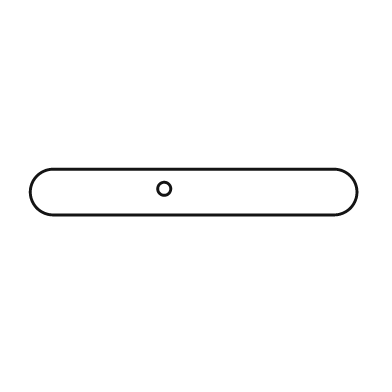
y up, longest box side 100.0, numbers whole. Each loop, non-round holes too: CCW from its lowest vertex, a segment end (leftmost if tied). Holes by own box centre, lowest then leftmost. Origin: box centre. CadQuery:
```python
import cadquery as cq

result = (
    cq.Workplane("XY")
    .moveTo(-43.0, -7.0)
    .lineTo(43.0, -7.0)
    .threePointArc((50.0, 0.0), (43.0, 7.0))
    .lineTo(-43.0, 7.0)
    .threePointArc((-50.0, 0.0), (-43.0, -7.0))
    .close()
    .moveTo(-9.0, 1.0)
    .circle(2.0)
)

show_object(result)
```